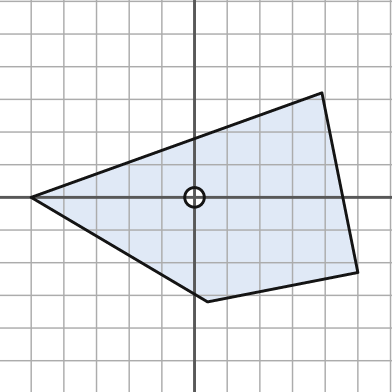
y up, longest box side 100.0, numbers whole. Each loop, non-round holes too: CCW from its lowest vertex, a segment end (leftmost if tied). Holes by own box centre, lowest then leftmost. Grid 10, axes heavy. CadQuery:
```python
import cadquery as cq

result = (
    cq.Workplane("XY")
    .moveTo(4.0, -32.0)
    .lineTo(50.0, -23.0)
    .lineTo(39.0, 32.0)
    .lineTo(-50.0, 0.0)
    .close()
    .moveTo(0.0, 0.0)
    .circle(3.0)
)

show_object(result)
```